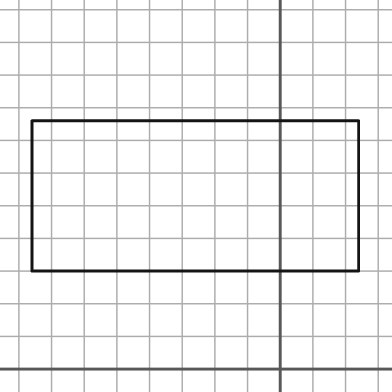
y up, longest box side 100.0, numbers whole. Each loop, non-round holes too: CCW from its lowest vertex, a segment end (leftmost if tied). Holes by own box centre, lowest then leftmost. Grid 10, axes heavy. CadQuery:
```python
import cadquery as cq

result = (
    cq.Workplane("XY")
    .moveTo(-76.0, 30.0)
    .lineTo(24.0, 30.0)
    .lineTo(24.0, 76.0)
    .lineTo(-76.0, 76.0)
    .close()
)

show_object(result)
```